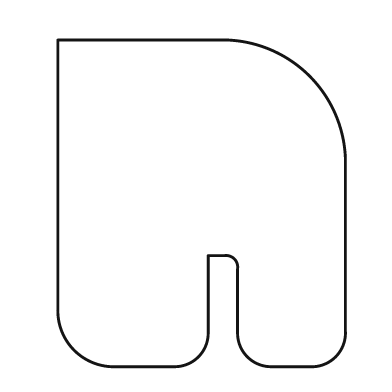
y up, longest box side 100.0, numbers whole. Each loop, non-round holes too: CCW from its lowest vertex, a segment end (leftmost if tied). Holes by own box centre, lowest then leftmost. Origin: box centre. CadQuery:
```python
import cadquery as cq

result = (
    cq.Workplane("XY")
    .moveTo(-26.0, -50.0)
    .lineTo(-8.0, -50.0)
    .threePointArc((-1.0, -47.0), (2.0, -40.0))
    .lineTo(2.0, -16.0)
    .lineTo(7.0, -16.0)
    .threePointArc((10.0, -17.0), (11.0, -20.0))
    .lineTo(11.0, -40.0)
    .threePointArc((14.0, -47.0), (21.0, -50.0))
    .lineTo(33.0, -50.0)
    .threePointArc((41.0, -47.0), (44.0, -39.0))
    .lineTo(44.0, 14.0)
    .threePointArc((33.0, 39.0), (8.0, 50.0))
    .lineTo(-44.0, 50.0)
    .lineTo(-44.0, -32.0)
    .threePointArc((-39.0, -45.0), (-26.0, -50.0))
    .close()
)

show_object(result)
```